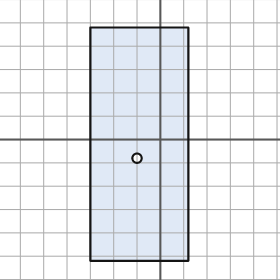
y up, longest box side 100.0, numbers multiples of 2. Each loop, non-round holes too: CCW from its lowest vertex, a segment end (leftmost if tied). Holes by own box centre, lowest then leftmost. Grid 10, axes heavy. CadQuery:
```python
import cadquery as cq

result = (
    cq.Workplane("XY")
    .moveTo(-30.0, -52.0)
    .lineTo(12.0, -52.0)
    .lineTo(12.0, 48.0)
    .lineTo(-30.0, 48.0)
    .close()
    .moveTo(-10.0, -8.0)
    .circle(2.0)
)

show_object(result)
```